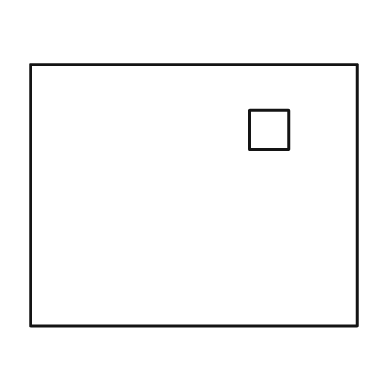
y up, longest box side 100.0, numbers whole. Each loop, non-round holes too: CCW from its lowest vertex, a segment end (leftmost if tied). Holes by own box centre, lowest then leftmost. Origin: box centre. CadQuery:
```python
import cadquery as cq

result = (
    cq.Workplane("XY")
    .moveTo(-50.0, -40.0)
    .lineTo(50.0, -40.0)
    .lineTo(50.0, 40.0)
    .lineTo(-50.0, 40.0)
    .close()
    .moveTo(17.0, 14.0)
    .lineTo(29.0, 14.0)
    .lineTo(29.0, 26.0)
    .lineTo(17.0, 26.0)
    .close()
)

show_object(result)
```